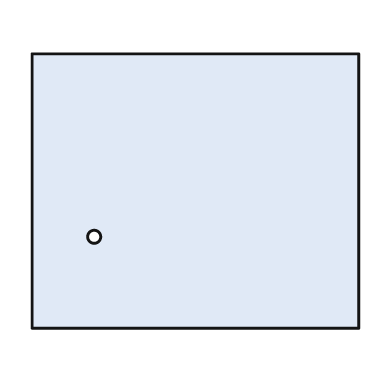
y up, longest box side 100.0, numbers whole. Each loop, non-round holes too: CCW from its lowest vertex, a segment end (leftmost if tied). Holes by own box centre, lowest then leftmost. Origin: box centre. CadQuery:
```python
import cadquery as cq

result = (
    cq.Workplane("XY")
    .moveTo(-50.0, -42.0)
    .lineTo(50.0, -42.0)
    .lineTo(50.0, 42.0)
    .lineTo(-50.0, 42.0)
    .close()
    .moveTo(-31.0, -14.0)
    .circle(2.0)
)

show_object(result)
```